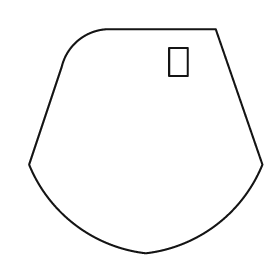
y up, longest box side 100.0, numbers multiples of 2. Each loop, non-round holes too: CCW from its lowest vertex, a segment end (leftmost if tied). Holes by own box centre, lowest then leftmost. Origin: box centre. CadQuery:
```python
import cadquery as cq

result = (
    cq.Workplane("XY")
    .moveTo(0.0, -48.0)
    .threePointArc((30.0, -36.0), (50.0, -10.0))
    .lineTo(30.0, 48.0)
    .lineTo(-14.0, 48.0)
    .threePointArc((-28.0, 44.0), (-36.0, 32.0))
    .lineTo(-50.0, -10.0)
    .threePointArc((-30.0, -36.0), (0.0, -48.0))
    .close()
    .moveTo(10.0, 28.0)
    .lineTo(18.0, 28.0)
    .lineTo(18.0, 40.0)
    .lineTo(10.0, 40.0)
    .close()
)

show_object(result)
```